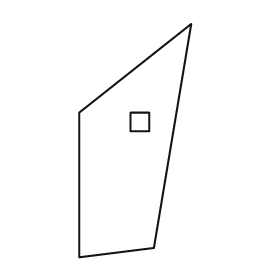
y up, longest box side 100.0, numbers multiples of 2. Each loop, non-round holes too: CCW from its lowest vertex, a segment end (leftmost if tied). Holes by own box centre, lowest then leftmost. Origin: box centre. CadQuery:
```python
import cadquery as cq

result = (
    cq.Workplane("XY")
    .moveTo(-24.0, -50.0)
    .lineTo(8.0, -46.0)
    .lineTo(24.0, 50.0)
    .lineTo(-24.0, 12.0)
    .close()
    .moveTo(-2.0, 4.0)
    .lineTo(6.0, 4.0)
    .lineTo(6.0, 12.0)
    .lineTo(-2.0, 12.0)
    .close()
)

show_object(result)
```